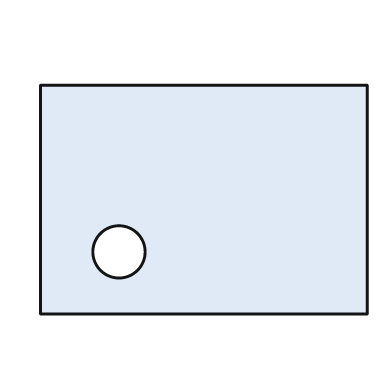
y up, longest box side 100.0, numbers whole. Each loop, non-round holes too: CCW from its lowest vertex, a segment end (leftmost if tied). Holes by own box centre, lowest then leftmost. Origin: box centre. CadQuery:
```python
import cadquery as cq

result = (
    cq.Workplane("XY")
    .moveTo(-50.0, -35.0)
    .lineTo(50.0, -35.0)
    .lineTo(50.0, 35.0)
    .lineTo(-50.0, 35.0)
    .close()
    .moveTo(-26.0, -16.0)
    .circle(8.0)
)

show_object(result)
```